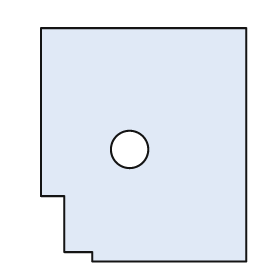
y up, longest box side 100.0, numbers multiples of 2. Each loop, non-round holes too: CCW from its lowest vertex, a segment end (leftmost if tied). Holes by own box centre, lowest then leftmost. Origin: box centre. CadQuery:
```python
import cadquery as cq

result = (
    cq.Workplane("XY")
    .moveTo(-22.0, -50.0)
    .lineTo(44.0, -50.0)
    .lineTo(44.0, 50.0)
    .lineTo(-44.0, 50.0)
    .lineTo(-44.0, -22.0)
    .lineTo(-34.0, -22.0)
    .lineTo(-34.0, -46.0)
    .lineTo(-22.0, -46.0)
    .close()
    .moveTo(-6.0, -2.0)
    .circle(8.0)
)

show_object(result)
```